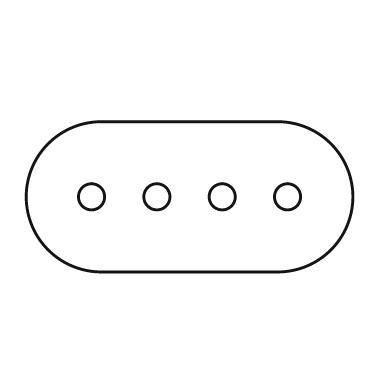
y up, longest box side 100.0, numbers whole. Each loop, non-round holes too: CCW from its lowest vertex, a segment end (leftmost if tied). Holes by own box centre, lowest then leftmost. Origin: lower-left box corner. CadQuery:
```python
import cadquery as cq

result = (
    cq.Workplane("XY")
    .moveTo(23.0, 0.0)
    .lineTo(77.0, 0.0)
    .threePointArc((100.0, 23.0), (77.0, 46.0))
    .lineTo(23.0, 46.0)
    .threePointArc((0.0, 23.0), (23.0, 0.0))
    .close()
    .moveTo(20.0, 23.0)
    .circle(4.0)
    .moveTo(40.0, 23.0)
    .circle(4.0)
    .moveTo(60.0, 23.0)
    .circle(4.0)
    .moveTo(80.0, 23.0)
    .circle(4.0)
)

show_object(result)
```